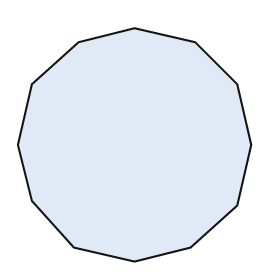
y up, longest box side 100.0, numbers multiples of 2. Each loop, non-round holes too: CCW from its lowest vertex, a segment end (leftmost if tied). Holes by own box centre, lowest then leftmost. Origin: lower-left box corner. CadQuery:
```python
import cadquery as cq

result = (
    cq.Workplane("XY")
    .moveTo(50.0, 0.0)
    .lineTo(74.0, 6.0)
    .lineTo(94.0, 24.0)
    .lineTo(100.0, 50.0)
    .lineTo(94.0, 76.0)
    .lineTo(76.0, 94.0)
    .lineTo(50.0, 100.0)
    .lineTo(26.0, 94.0)
    .lineTo(6.0, 76.0)
    .lineTo(0.0, 50.0)
    .lineTo(6.0, 26.0)
    .lineTo(24.0, 6.0)
    .close()
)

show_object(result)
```